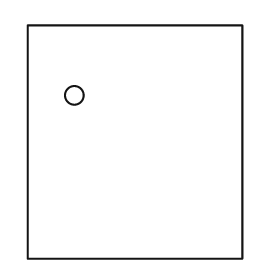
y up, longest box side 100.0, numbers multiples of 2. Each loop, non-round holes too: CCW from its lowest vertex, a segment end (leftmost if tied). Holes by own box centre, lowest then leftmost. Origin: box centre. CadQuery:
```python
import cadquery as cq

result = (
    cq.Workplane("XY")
    .moveTo(-46.0, -50.0)
    .lineTo(46.0, -50.0)
    .lineTo(46.0, 50.0)
    .lineTo(-46.0, 50.0)
    .close()
    .moveTo(-26.0, 20.0)
    .circle(4.0)
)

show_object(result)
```